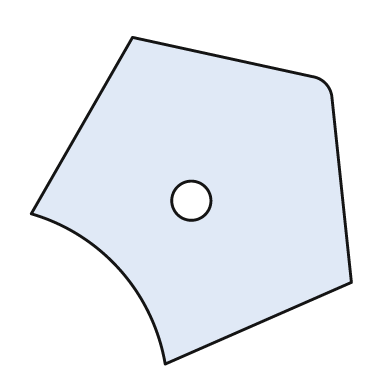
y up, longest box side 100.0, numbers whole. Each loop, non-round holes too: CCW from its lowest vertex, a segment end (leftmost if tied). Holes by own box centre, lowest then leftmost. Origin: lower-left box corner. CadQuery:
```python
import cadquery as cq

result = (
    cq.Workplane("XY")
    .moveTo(41.0, 0.0)
    .lineTo(98.0, 25.0)
    .lineTo(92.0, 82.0)
    .threePointArc((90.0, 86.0), (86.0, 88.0))
    .lineTo(31.0, 100.0)
    .lineTo(0.0, 46.0)
    .threePointArc((27.0, 29.0), (41.0, 0.0))
    .close()
    .moveTo(49.0, 50.0)
    .circle(6.0)
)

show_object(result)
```